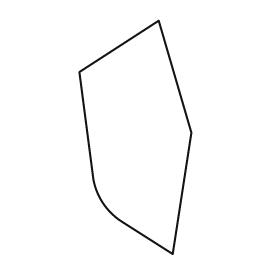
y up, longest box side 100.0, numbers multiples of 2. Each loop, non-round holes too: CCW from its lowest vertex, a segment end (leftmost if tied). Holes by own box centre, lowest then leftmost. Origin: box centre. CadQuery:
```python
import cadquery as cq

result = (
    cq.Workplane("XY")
    .moveTo(16.0, -50.0)
    .lineTo(24.0, 2.0)
    .lineTo(10.0, 50.0)
    .lineTo(-24.0, 28.0)
    .lineTo(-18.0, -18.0)
    .threePointArc((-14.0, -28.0), (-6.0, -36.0))
    .close()
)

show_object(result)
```